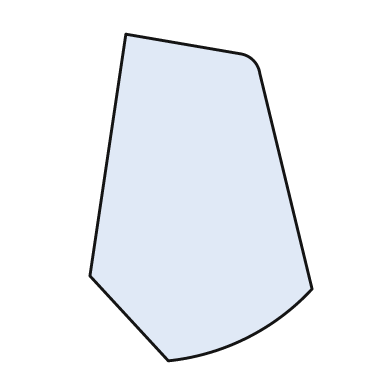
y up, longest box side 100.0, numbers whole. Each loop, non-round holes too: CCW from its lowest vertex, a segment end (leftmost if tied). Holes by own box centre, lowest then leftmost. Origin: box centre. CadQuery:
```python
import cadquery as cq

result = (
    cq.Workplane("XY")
    .moveTo(-10.0, -50.0)
    .threePointArc((14.0, -43.0), (34.0, -28.0))
    .lineTo(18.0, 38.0)
    .threePointArc((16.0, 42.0), (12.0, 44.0))
    .lineTo(-23.0, 50.0)
    .lineTo(-34.0, -24.0)
    .close()
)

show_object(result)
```